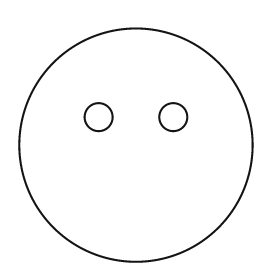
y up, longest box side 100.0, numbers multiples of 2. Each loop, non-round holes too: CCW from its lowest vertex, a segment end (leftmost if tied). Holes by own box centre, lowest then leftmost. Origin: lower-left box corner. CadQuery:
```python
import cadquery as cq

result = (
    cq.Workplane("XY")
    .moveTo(50.0, 50.0)
    .circle(50.0)
    .moveTo(34.0, 62.0)
    .circle(6.0)
    .moveTo(66.0, 62.0)
    .circle(6.0)
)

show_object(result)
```